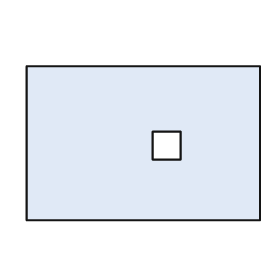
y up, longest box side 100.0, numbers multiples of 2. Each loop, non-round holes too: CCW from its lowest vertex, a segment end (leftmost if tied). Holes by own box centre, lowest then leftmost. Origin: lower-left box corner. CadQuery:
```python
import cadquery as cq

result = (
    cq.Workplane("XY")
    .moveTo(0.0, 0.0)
    .lineTo(100.0, 0.0)
    .lineTo(100.0, 66.0)
    .lineTo(0.0, 66.0)
    .close()
    .moveTo(54.0, 26.0)
    .lineTo(66.0, 26.0)
    .lineTo(66.0, 38.0)
    .lineTo(54.0, 38.0)
    .close()
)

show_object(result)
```